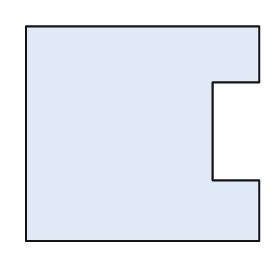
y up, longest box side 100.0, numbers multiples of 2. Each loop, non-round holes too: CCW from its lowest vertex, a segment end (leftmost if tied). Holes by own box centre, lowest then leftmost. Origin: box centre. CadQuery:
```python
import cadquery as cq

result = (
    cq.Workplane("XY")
    .moveTo(-50.0, -46.0)
    .lineTo(50.0, -46.0)
    .lineTo(50.0, -20.0)
    .lineTo(30.0, -20.0)
    .lineTo(30.0, 22.0)
    .lineTo(50.0, 22.0)
    .lineTo(50.0, 46.0)
    .lineTo(-50.0, 46.0)
    .close()
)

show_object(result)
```